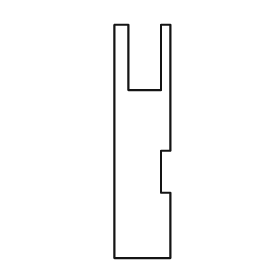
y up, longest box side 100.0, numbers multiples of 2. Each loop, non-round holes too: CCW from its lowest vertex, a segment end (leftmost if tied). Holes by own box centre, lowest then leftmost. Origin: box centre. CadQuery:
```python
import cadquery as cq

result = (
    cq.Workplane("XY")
    .moveTo(-12.0, -50.0)
    .lineTo(12.0, -50.0)
    .lineTo(12.0, -22.0)
    .lineTo(8.0, -22.0)
    .lineTo(8.0, -4.0)
    .lineTo(12.0, -4.0)
    .lineTo(12.0, 50.0)
    .lineTo(8.0, 50.0)
    .lineTo(8.0, 22.0)
    .lineTo(-6.0, 22.0)
    .lineTo(-6.0, 50.0)
    .lineTo(-12.0, 50.0)
    .close()
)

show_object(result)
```